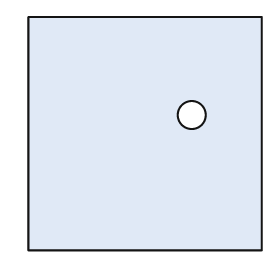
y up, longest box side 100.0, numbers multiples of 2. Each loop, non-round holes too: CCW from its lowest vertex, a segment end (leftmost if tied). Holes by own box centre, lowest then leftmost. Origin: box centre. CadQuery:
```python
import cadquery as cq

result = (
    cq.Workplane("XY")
    .moveTo(-50.0, -50.0)
    .lineTo(50.0, -50.0)
    .lineTo(50.0, 50.0)
    .lineTo(-50.0, 50.0)
    .close()
    .moveTo(20.0, 8.0)
    .circle(6.0)
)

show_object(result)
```